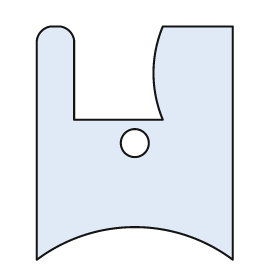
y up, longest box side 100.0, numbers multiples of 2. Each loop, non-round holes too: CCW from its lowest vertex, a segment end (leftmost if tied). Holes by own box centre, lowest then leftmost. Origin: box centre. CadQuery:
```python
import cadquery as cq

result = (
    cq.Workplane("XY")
    .moveTo(-42.0, -50.0)
    .threePointArc((0.0, -36.0), (42.0, -50.0))
    .lineTo(42.0, 50.0)
    .lineTo(12.0, 50.0)
    .threePointArc((8.0, 30.0), (12.0, 10.0))
    .lineTo(-26.0, 10.0)
    .lineTo(-26.0, 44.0)
    .threePointArc((-28.0, 48.0), (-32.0, 50.0))
    .lineTo(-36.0, 50.0)
    .threePointArc((-40.0, 48.0), (-42.0, 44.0))
    .close()
    .moveTo(0.0, 0.0)
    .circle(6.0)
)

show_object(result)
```